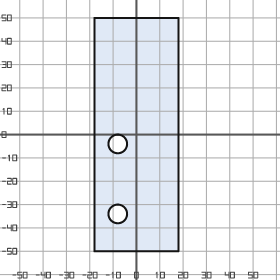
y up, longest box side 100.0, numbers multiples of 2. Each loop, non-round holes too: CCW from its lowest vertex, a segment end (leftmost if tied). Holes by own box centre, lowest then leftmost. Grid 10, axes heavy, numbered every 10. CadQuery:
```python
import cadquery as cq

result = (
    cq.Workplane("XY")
    .moveTo(-18.0, -50.0)
    .lineTo(18.0, -50.0)
    .lineTo(18.0, 50.0)
    .lineTo(-18.0, 50.0)
    .close()
    .moveTo(-8.0, -34.0)
    .circle(4.0)
    .moveTo(-8.0, -4.0)
    .circle(4.0)
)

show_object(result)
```